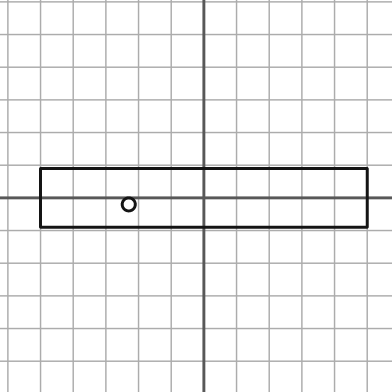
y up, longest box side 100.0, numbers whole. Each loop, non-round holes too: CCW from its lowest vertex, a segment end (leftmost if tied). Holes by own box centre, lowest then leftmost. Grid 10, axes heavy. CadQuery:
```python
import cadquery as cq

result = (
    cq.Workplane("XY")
    .moveTo(-50.0, -9.0)
    .lineTo(50.0, -9.0)
    .lineTo(50.0, 9.0)
    .lineTo(-50.0, 9.0)
    .close()
    .moveTo(-23.0, -2.0)
    .circle(2.0)
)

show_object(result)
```